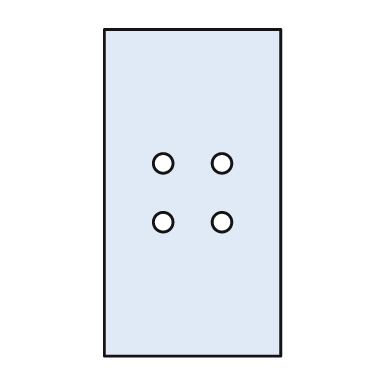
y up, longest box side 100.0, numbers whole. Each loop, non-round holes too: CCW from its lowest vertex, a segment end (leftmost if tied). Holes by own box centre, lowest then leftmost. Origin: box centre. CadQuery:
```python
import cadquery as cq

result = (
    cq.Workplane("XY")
    .moveTo(-27.0, -50.0)
    .lineTo(27.0, -50.0)
    .lineTo(27.0, 50.0)
    .lineTo(-27.0, 50.0)
    .close()
    .moveTo(-9.0, -9.0)
    .circle(3.0)
    .moveTo(9.0, -9.0)
    .circle(3.0)
    .moveTo(-9.0, 9.0)
    .circle(3.0)
    .moveTo(9.0, 9.0)
    .circle(3.0)
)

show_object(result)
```